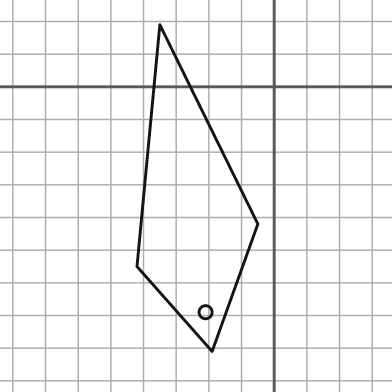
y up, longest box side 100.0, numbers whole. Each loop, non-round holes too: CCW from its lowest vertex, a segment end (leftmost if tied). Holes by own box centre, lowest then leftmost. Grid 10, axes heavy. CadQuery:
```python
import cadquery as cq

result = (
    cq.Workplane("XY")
    .moveTo(-19.0, -81.0)
    .lineTo(-5.0, -42.0)
    .lineTo(-35.0, 19.0)
    .lineTo(-42.0, -55.0)
    .close()
    .moveTo(-21.0, -69.0)
    .circle(2.0)
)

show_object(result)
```